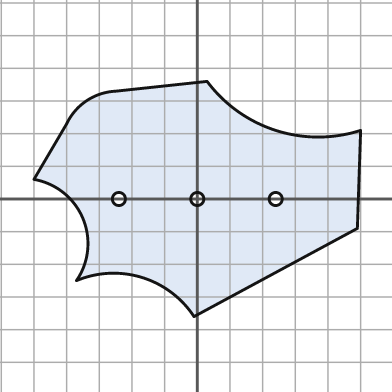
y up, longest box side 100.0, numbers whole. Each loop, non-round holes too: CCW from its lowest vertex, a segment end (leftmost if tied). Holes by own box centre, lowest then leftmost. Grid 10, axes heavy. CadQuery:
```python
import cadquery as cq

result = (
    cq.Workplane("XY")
    .moveTo(-1.0, -36.0)
    .lineTo(49.0, -9.0)
    .lineTo(50.0, 21.0)
    .threePointArc((24.0, 21.0), (3.0, 36.0))
    .lineTo(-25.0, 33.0)
    .threePointArc((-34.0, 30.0), (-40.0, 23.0))
    .lineTo(-50.0, 6.0)
    .threePointArc((-35.0, -6.0), (-37.0, -25.0))
    .threePointArc((-17.0, -24.0), (-1.0, -36.0))
    .close()
    .moveTo(-24.0, 0.0)
    .circle(2.0)
    .moveTo(0.0, 0.0)
    .circle(2.0)
    .moveTo(24.0, 0.0)
    .circle(2.0)
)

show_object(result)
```